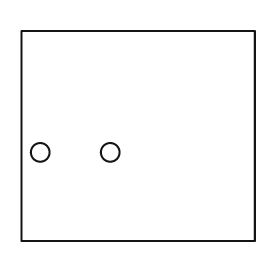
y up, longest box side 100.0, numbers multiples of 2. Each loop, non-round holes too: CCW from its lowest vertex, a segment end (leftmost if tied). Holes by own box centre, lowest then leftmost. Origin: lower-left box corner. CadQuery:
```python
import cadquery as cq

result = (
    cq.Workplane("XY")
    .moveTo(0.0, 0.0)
    .lineTo(100.0, 0.0)
    .lineTo(100.0, 90.0)
    .lineTo(0.0, 90.0)
    .close()
    .moveTo(8.0, 38.0)
    .circle(4.0)
    .moveTo(38.0, 38.0)
    .circle(4.0)
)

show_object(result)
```